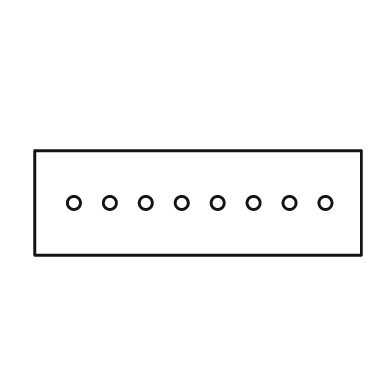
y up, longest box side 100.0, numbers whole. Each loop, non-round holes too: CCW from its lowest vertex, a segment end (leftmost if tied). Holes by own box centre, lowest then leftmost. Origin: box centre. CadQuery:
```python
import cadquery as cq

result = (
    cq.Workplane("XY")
    .moveTo(-50.0, -16.0)
    .lineTo(50.0, -16.0)
    .lineTo(50.0, 16.0)
    .lineTo(-50.0, 16.0)
    .close()
    .moveTo(-38.0, 0.0)
    .circle(2.0)
    .moveTo(-27.0, 0.0)
    .circle(2.0)
    .moveTo(-16.0, 0.0)
    .circle(2.0)
    .moveTo(-5.0, 0.0)
    .circle(2.0)
    .moveTo(6.0, 0.0)
    .circle(2.0)
    .moveTo(17.0, 0.0)
    .circle(2.0)
    .moveTo(28.0, 0.0)
    .circle(2.0)
    .moveTo(39.0, 0.0)
    .circle(2.0)
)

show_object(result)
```